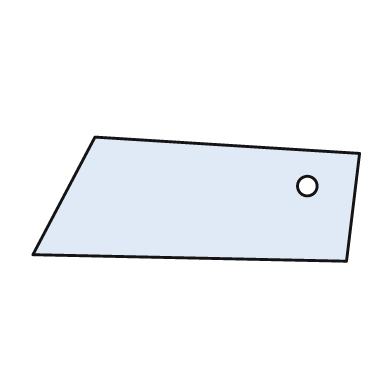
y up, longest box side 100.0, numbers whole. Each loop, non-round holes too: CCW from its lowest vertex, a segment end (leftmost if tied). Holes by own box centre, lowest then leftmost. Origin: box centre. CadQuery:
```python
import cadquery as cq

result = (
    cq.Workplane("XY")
    .moveTo(46.0, -19.0)
    .lineTo(50.0, 14.0)
    .lineTo(-31.0, 19.0)
    .lineTo(-50.0, -17.0)
    .close()
    .moveTo(34.0, 4.0)
    .circle(3.0)
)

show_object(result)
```